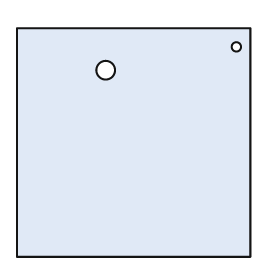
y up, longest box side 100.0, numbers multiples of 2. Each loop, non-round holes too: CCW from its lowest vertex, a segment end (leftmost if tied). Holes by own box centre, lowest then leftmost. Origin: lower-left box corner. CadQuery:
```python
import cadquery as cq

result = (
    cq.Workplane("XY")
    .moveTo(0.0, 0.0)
    .lineTo(100.0, 0.0)
    .lineTo(100.0, 98.0)
    .lineTo(0.0, 98.0)
    .close()
    .moveTo(38.0, 80.0)
    .circle(4.0)
    .moveTo(94.0, 90.0)
    .circle(2.0)
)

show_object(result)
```